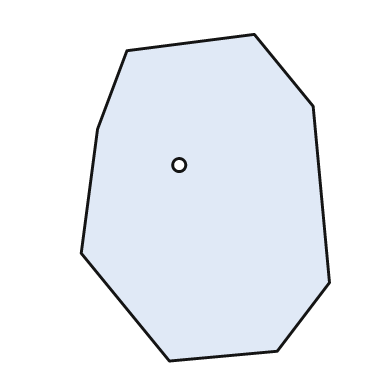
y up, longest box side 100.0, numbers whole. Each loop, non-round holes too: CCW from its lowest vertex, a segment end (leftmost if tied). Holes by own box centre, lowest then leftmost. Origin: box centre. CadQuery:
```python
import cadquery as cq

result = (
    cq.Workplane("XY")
    .moveTo(-11.0, -50.0)
    .lineTo(22.0, -47.0)
    .lineTo(38.0, -26.0)
    .lineTo(33.0, 28.0)
    .lineTo(15.0, 50.0)
    .lineTo(-24.0, 45.0)
    .lineTo(-33.0, 21.0)
    .lineTo(-38.0, -17.0)
    .close()
    .moveTo(-8.0, 10.0)
    .circle(2.0)
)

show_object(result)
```